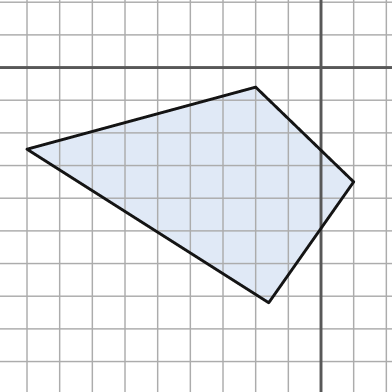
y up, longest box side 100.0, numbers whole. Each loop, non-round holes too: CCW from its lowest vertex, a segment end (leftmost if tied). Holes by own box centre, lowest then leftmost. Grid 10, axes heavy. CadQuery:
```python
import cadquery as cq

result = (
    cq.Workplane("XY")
    .moveTo(-16.0, -72.0)
    .lineTo(10.0, -35.0)
    .lineTo(-20.0, -6.0)
    .lineTo(-90.0, -25.0)
    .close()
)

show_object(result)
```